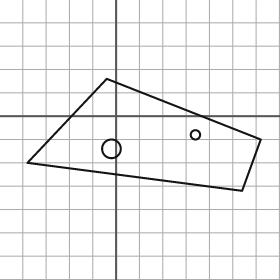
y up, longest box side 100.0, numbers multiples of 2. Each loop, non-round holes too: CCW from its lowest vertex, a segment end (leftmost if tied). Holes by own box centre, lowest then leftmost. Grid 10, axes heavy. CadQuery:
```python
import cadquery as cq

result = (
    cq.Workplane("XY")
    .moveTo(54.0, -32.0)
    .lineTo(62.0, -10.0)
    .lineTo(-4.0, 16.0)
    .lineTo(-38.0, -20.0)
    .close()
    .moveTo(-2.0, -14.0)
    .circle(4.0)
    .moveTo(34.0, -8.0)
    .circle(2.0)
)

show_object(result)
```